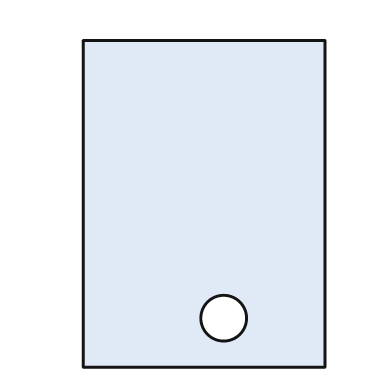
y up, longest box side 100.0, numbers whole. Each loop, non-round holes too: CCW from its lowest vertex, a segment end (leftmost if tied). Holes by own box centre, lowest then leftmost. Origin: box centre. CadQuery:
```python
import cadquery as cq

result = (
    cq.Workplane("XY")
    .moveTo(-37.0, -50.0)
    .lineTo(37.0, -50.0)
    .lineTo(37.0, 50.0)
    .lineTo(-37.0, 50.0)
    .close()
    .moveTo(6.0, -35.0)
    .circle(7.0)
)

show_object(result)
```